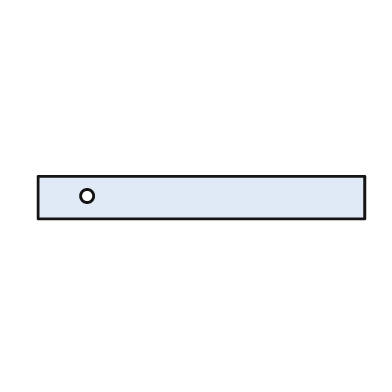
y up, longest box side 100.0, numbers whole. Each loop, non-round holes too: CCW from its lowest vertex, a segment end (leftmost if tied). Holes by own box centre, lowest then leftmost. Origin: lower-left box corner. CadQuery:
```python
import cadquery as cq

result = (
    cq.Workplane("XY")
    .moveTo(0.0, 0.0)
    .lineTo(100.0, 0.0)
    .lineTo(100.0, 13.0)
    .lineTo(0.0, 13.0)
    .close()
    .moveTo(15.0, 7.0)
    .circle(2.0)
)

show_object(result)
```